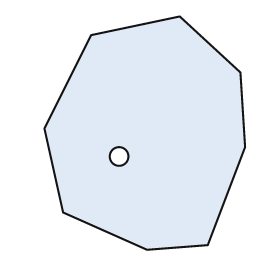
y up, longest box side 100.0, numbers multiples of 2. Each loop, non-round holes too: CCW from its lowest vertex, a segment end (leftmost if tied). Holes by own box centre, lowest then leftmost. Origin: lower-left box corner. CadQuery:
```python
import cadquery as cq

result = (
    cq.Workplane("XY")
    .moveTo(44.0, 0.0)
    .lineTo(70.0, 2.0)
    .lineTo(86.0, 44.0)
    .lineTo(84.0, 76.0)
    .lineTo(58.0, 100.0)
    .lineTo(20.0, 92.0)
    .lineTo(0.0, 52.0)
    .lineTo(8.0, 16.0)
    .close()
    .moveTo(32.0, 40.0)
    .circle(4.0)
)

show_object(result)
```